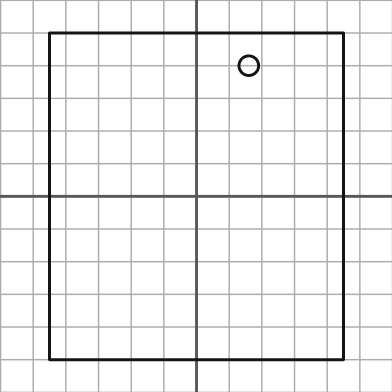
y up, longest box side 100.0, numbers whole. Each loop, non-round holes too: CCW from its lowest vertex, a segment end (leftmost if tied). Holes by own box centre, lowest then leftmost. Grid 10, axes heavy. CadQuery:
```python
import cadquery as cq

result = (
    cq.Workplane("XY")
    .moveTo(-45.0, -50.0)
    .lineTo(45.0, -50.0)
    .lineTo(45.0, 50.0)
    .lineTo(-45.0, 50.0)
    .close()
    .moveTo(16.0, 40.0)
    .circle(3.0)
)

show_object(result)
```